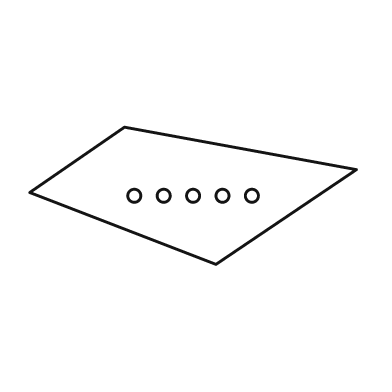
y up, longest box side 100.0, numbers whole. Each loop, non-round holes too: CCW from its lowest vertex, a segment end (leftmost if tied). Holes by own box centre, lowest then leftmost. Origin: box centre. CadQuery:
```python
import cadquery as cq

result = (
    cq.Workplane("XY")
    .moveTo(7.0, -21.0)
    .lineTo(50.0, 8.0)
    .lineTo(-21.0, 21.0)
    .lineTo(-50.0, 1.0)
    .close()
    .moveTo(-18.0, 0.0)
    .circle(2.0)
    .moveTo(-9.0, 0.0)
    .circle(2.0)
    .moveTo(0.0, 0.0)
    .circle(2.0)
    .moveTo(9.0, 0.0)
    .circle(2.0)
    .moveTo(18.0, 0.0)
    .circle(2.0)
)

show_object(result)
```